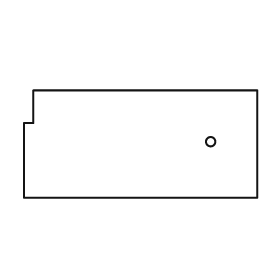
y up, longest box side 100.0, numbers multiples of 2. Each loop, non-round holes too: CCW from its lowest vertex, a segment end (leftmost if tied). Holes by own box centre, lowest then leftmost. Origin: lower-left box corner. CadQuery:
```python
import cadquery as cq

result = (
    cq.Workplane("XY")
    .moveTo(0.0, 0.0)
    .lineTo(100.0, 0.0)
    .lineTo(100.0, 46.0)
    .lineTo(4.0, 46.0)
    .lineTo(4.0, 32.0)
    .lineTo(0.0, 32.0)
    .close()
    .moveTo(80.0, 24.0)
    .circle(2.0)
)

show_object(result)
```